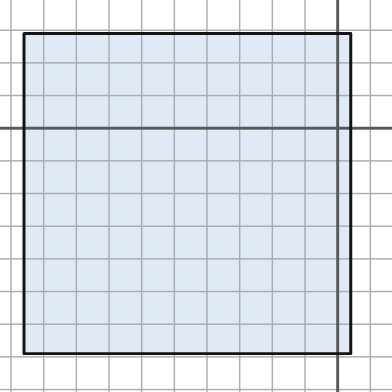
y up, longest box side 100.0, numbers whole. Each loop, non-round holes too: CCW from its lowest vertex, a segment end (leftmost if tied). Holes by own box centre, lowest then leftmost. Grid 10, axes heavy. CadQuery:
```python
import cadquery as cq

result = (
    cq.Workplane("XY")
    .moveTo(-96.0, -69.0)
    .lineTo(4.0, -69.0)
    .lineTo(4.0, 29.0)
    .lineTo(-96.0, 29.0)
    .close()
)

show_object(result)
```